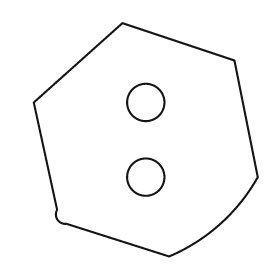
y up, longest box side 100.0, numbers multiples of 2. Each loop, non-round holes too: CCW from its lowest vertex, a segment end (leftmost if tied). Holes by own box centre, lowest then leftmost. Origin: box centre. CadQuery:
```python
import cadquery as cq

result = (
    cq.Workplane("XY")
    .moveTo(10.0, -50.0)
    .threePointArc((32.0, -36.0), (48.0, -16.0))
    .lineTo(38.0, 34.0)
    .lineTo(-10.0, 50.0)
    .lineTo(-48.0, 16.0)
    .lineTo(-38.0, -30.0)
    .threePointArc((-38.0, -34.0), (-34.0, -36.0))
    .close()
    .moveTo(0.0, -16.0)
    .circle(8.0)
    .moveTo(0.0, 16.0)
    .circle(8.0)
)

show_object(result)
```